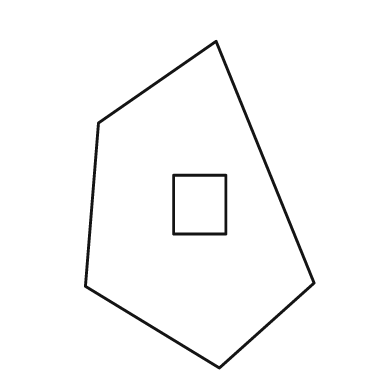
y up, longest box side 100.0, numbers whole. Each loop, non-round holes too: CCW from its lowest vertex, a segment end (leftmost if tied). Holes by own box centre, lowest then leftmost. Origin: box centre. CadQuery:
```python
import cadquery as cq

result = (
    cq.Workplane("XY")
    .moveTo(6.0, -50.0)
    .lineTo(35.0, -24.0)
    .lineTo(5.0, 50.0)
    .lineTo(-31.0, 25.0)
    .lineTo(-35.0, -25.0)
    .close()
    .moveTo(-8.0, -9.0)
    .lineTo(8.0, -9.0)
    .lineTo(8.0, 9.0)
    .lineTo(-8.0, 9.0)
    .close()
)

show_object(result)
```